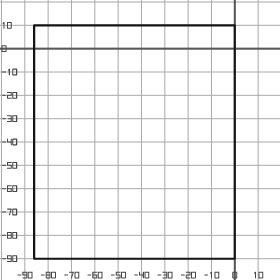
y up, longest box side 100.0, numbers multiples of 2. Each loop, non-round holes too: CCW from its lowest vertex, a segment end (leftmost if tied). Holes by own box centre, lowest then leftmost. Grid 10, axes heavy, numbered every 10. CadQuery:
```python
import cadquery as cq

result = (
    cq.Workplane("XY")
    .moveTo(-86.0, -90.0)
    .lineTo(0.0, -90.0)
    .lineTo(0.0, 10.0)
    .lineTo(-86.0, 10.0)
    .close()
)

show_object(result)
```